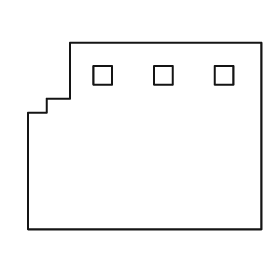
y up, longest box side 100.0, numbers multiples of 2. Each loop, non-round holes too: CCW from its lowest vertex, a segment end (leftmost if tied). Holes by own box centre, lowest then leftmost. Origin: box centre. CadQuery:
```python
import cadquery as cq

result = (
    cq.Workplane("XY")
    .moveTo(-50.0, -40.0)
    .lineTo(50.0, -40.0)
    .lineTo(50.0, 40.0)
    .lineTo(-32.0, 40.0)
    .lineTo(-32.0, 16.0)
    .lineTo(-42.0, 16.0)
    .lineTo(-42.0, 10.0)
    .lineTo(-50.0, 10.0)
    .close()
    .moveTo(-22.0, 22.0)
    .lineTo(-14.0, 22.0)
    .lineTo(-14.0, 30.0)
    .lineTo(-22.0, 30.0)
    .close()
    .moveTo(4.0, 22.0)
    .lineTo(12.0, 22.0)
    .lineTo(12.0, 30.0)
    .lineTo(4.0, 30.0)
    .close()
    .moveTo(30.0, 22.0)
    .lineTo(38.0, 22.0)
    .lineTo(38.0, 30.0)
    .lineTo(30.0, 30.0)
    .close()
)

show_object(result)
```